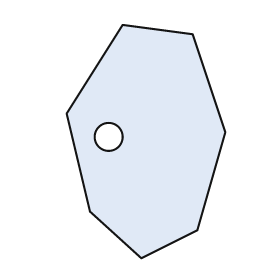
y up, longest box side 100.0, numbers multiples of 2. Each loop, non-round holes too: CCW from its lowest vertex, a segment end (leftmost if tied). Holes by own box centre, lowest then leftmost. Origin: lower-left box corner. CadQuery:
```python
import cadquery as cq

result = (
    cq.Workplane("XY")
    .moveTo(32.0, 0.0)
    .lineTo(56.0, 12.0)
    .lineTo(68.0, 54.0)
    .lineTo(54.0, 96.0)
    .lineTo(24.0, 100.0)
    .lineTo(0.0, 62.0)
    .lineTo(10.0, 20.0)
    .close()
    .moveTo(18.0, 52.0)
    .circle(6.0)
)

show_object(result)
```